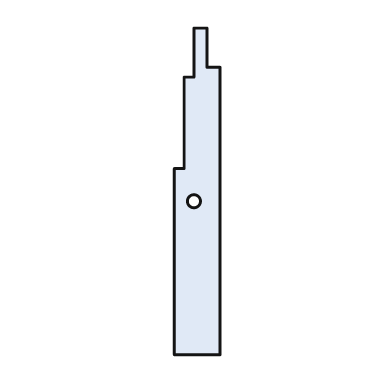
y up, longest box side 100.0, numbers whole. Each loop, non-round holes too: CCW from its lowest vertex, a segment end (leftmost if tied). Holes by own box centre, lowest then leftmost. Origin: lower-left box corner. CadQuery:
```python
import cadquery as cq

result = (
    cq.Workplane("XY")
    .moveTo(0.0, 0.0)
    .lineTo(14.0, 0.0)
    .lineTo(14.0, 88.0)
    .lineTo(10.0, 88.0)
    .lineTo(10.0, 100.0)
    .lineTo(6.0, 100.0)
    .lineTo(6.0, 85.0)
    .lineTo(3.0, 85.0)
    .lineTo(3.0, 57.0)
    .lineTo(0.0, 57.0)
    .close()
    .moveTo(6.0, 47.0)
    .circle(2.0)
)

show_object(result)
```